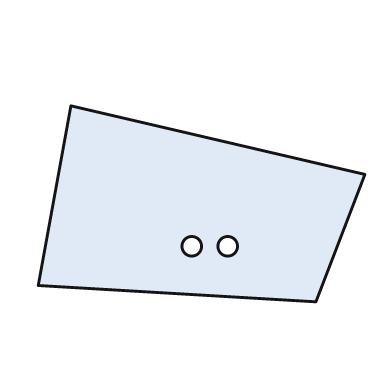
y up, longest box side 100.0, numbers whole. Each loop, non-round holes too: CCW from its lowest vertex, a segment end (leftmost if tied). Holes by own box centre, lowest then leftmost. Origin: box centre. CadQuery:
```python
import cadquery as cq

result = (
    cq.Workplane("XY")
    .moveTo(35.0, -30.0)
    .lineTo(50.0, 9.0)
    .lineTo(-40.0, 30.0)
    .lineTo(-50.0, -25.0)
    .close()
    .moveTo(-3.0, -13.0)
    .circle(3.0)
    .moveTo(8.0, -13.0)
    .circle(3.0)
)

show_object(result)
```